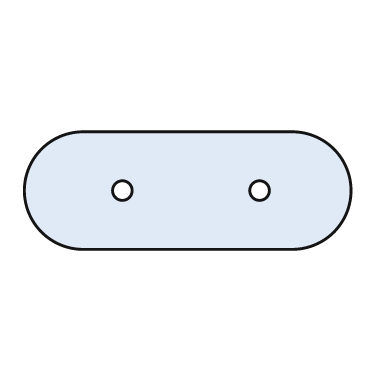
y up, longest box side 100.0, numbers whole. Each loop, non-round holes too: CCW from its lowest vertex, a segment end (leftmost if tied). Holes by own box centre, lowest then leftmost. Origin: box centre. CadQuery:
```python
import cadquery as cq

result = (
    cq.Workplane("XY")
    .moveTo(-32.0, -18.0)
    .lineTo(32.0, -18.0)
    .threePointArc((50.0, 0.0), (32.0, 18.0))
    .lineTo(-32.0, 18.0)
    .threePointArc((-50.0, 0.0), (-32.0, -18.0))
    .close()
    .moveTo(-20.0, 0.0)
    .circle(3.0)
    .moveTo(22.0, 0.0)
    .circle(3.0)
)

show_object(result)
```